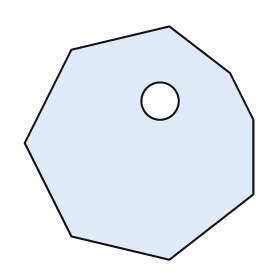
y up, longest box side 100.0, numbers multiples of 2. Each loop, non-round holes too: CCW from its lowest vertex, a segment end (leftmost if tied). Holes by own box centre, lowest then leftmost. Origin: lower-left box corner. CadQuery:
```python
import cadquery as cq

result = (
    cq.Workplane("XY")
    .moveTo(62.0, 0.0)
    .lineTo(98.0, 28.0)
    .lineTo(98.0, 60.0)
    .lineTo(88.0, 80.0)
    .lineTo(62.0, 100.0)
    .lineTo(20.0, 90.0)
    .lineTo(0.0, 50.0)
    .lineTo(20.0, 10.0)
    .close()
    .moveTo(58.0, 68.0)
    .circle(8.0)
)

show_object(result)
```